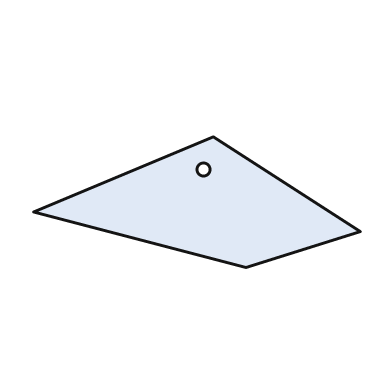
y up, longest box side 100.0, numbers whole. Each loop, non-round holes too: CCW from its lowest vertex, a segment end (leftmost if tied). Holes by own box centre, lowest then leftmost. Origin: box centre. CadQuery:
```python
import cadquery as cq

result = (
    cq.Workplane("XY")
    .moveTo(15.0, -20.0)
    .lineTo(50.0, -9.0)
    .lineTo(5.0, 20.0)
    .lineTo(-50.0, -3.0)
    .close()
    .moveTo(2.0, 10.0)
    .circle(2.0)
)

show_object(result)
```